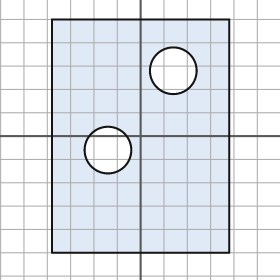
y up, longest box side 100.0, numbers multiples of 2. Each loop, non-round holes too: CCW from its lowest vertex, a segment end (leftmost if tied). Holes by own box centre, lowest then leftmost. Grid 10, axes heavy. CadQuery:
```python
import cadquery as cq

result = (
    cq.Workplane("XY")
    .moveTo(-38.0, -50.0)
    .lineTo(38.0, -50.0)
    .lineTo(38.0, 50.0)
    .lineTo(-38.0, 50.0)
    .close()
    .moveTo(-14.0, -6.0)
    .circle(10.0)
    .moveTo(14.0, 28.0)
    .circle(10.0)
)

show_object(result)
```